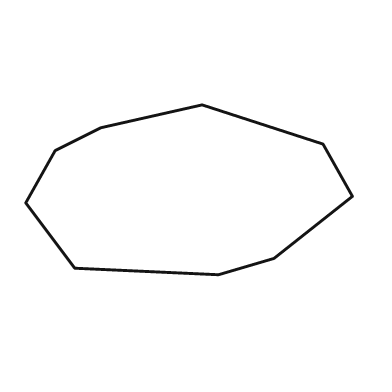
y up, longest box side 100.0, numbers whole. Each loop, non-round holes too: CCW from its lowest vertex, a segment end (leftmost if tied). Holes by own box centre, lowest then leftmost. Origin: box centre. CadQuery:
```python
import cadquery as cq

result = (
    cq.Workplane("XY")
    .moveTo(9.0, -26.0)
    .lineTo(26.0, -21.0)
    .lineTo(50.0, -2.0)
    .lineTo(41.0, 14.0)
    .lineTo(4.0, 26.0)
    .lineTo(-27.0, 19.0)
    .lineTo(-41.0, 12.0)
    .lineTo(-50.0, -4.0)
    .lineTo(-35.0, -24.0)
    .close()
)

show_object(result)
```